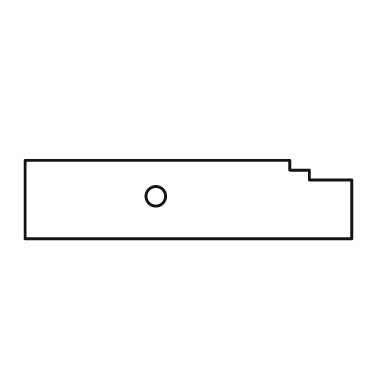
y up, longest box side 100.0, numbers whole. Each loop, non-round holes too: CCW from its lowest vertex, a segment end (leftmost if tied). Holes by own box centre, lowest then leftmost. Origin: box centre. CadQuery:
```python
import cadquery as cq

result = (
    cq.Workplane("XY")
    .moveTo(-50.0, -12.0)
    .lineTo(50.0, -12.0)
    .lineTo(50.0, 6.0)
    .lineTo(37.0, 6.0)
    .lineTo(37.0, 9.0)
    .lineTo(31.0, 9.0)
    .lineTo(31.0, 12.0)
    .lineTo(-50.0, 12.0)
    .close()
    .moveTo(-10.0, 1.0)
    .circle(3.0)
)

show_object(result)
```